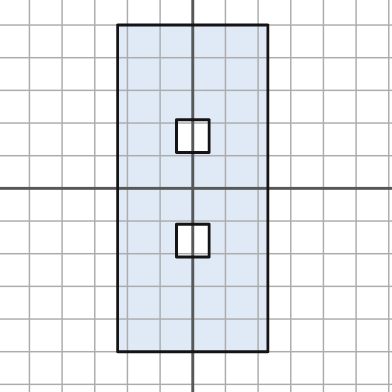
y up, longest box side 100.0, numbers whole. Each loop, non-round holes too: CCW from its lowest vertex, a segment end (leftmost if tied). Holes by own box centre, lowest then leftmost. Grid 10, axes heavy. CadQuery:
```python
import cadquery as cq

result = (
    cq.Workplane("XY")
    .moveTo(-23.0, -50.0)
    .lineTo(23.0, -50.0)
    .lineTo(23.0, 50.0)
    .lineTo(-23.0, 50.0)
    .close()
    .moveTo(-5.0, -21.0)
    .lineTo(5.0, -21.0)
    .lineTo(5.0, -11.0)
    .lineTo(-5.0, -11.0)
    .close()
    .moveTo(-5.0, 11.0)
    .lineTo(5.0, 11.0)
    .lineTo(5.0, 21.0)
    .lineTo(-5.0, 21.0)
    .close()
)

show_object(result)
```